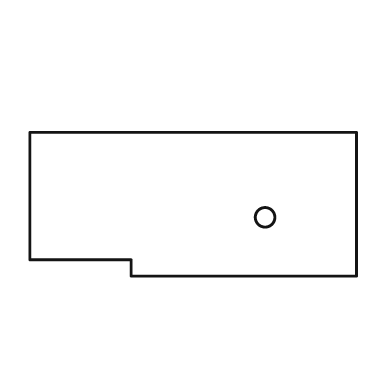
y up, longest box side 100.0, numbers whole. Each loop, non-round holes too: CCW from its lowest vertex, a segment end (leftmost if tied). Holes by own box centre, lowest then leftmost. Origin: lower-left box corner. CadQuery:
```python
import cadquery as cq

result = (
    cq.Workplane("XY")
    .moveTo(31.0, 0.0)
    .lineTo(100.0, 0.0)
    .lineTo(100.0, 44.0)
    .lineTo(0.0, 44.0)
    .lineTo(0.0, 5.0)
    .lineTo(31.0, 5.0)
    .close()
    .moveTo(72.0, 18.0)
    .circle(3.0)
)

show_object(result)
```